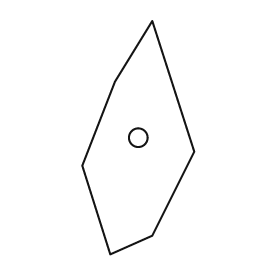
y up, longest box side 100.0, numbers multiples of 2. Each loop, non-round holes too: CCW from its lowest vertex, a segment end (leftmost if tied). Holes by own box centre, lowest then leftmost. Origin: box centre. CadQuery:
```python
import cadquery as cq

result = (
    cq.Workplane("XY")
    .moveTo(-12.0, -50.0)
    .lineTo(6.0, -42.0)
    .lineTo(24.0, -6.0)
    .lineTo(6.0, 50.0)
    .lineTo(-10.0, 24.0)
    .lineTo(-24.0, -12.0)
    .close()
    .moveTo(0.0, 0.0)
    .circle(4.0)
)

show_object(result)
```